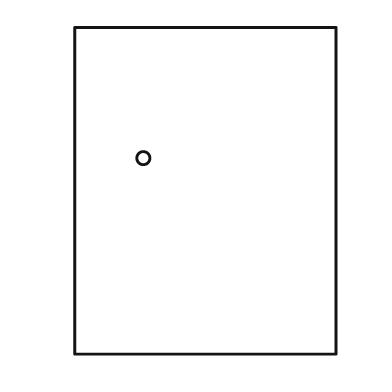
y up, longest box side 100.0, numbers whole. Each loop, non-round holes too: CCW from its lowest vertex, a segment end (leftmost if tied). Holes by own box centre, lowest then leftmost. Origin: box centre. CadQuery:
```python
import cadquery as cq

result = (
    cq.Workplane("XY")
    .moveTo(-40.0, -50.0)
    .lineTo(40.0, -50.0)
    .lineTo(40.0, 50.0)
    .lineTo(-40.0, 50.0)
    .close()
    .moveTo(-19.0, 10.0)
    .circle(2.0)
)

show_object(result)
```